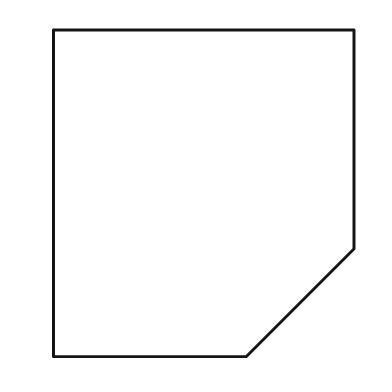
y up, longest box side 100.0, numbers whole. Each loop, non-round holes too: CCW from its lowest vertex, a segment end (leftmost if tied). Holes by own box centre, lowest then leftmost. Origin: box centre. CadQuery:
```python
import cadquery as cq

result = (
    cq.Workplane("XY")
    .moveTo(-46.0, -50.0)
    .lineTo(13.0, -50.0)
    .lineTo(46.0, -17.0)
    .lineTo(46.0, 50.0)
    .lineTo(-46.0, 50.0)
    .close()
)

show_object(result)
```